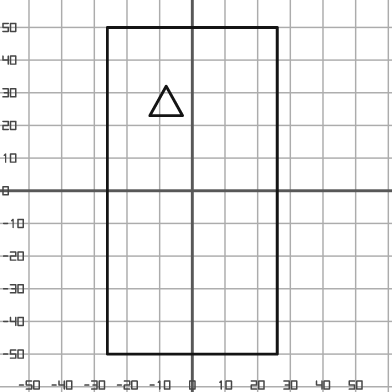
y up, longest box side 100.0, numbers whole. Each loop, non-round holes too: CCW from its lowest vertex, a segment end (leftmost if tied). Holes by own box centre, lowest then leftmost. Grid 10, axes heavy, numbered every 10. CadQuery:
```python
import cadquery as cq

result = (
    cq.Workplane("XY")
    .moveTo(-26.0, -50.0)
    .lineTo(26.0, -50.0)
    .lineTo(26.0, 50.0)
    .lineTo(-26.0, 50.0)
    .close()
    .moveTo(-13.0, 23.0)
    .lineTo(-3.0, 23.0)
    .lineTo(-8.0, 32.0)
    .close()
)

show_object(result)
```